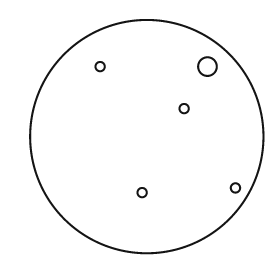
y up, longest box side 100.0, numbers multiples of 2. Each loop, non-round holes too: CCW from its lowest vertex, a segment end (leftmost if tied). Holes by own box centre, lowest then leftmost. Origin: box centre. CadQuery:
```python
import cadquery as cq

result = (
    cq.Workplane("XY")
    .moveTo(0.0, 0.0)
    .circle(50.0)
    .moveTo(-2.0, -24.0)
    .circle(2.0)
    .moveTo(38.0, -22.0)
    .circle(2.0)
    .moveTo(16.0, 12.0)
    .circle(2.0)
    .moveTo(-20.0, 30.0)
    .circle(2.0)
    .moveTo(26.0, 30.0)
    .circle(4.0)
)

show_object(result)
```